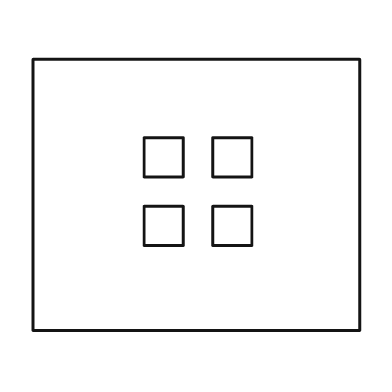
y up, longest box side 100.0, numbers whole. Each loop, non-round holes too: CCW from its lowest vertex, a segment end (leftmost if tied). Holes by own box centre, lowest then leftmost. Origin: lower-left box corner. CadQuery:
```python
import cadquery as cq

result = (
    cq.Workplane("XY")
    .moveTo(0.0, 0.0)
    .lineTo(100.0, 0.0)
    .lineTo(100.0, 83.0)
    .lineTo(0.0, 83.0)
    .close()
    .moveTo(34.0, 26.0)
    .lineTo(46.0, 26.0)
    .lineTo(46.0, 38.0)
    .lineTo(34.0, 38.0)
    .close()
    .moveTo(55.0, 26.0)
    .lineTo(67.0, 26.0)
    .lineTo(67.0, 38.0)
    .lineTo(55.0, 38.0)
    .close()
    .moveTo(34.0, 47.0)
    .lineTo(46.0, 47.0)
    .lineTo(46.0, 59.0)
    .lineTo(34.0, 59.0)
    .close()
    .moveTo(55.0, 47.0)
    .lineTo(67.0, 47.0)
    .lineTo(67.0, 59.0)
    .lineTo(55.0, 59.0)
    .close()
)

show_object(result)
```